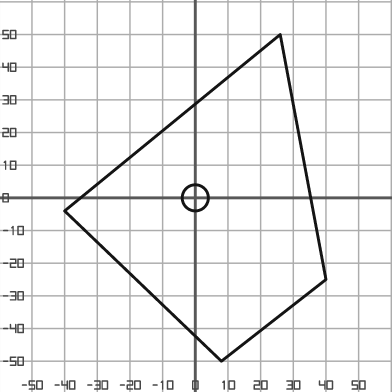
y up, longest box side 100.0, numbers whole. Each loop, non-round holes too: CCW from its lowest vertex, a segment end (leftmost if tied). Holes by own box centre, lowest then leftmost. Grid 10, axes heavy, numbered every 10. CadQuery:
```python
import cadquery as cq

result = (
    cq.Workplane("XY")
    .moveTo(8.0, -50.0)
    .lineTo(40.0, -25.0)
    .lineTo(26.0, 50.0)
    .lineTo(-40.0, -4.0)
    .close()
    .moveTo(0.0, 0.0)
    .circle(4.0)
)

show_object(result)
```